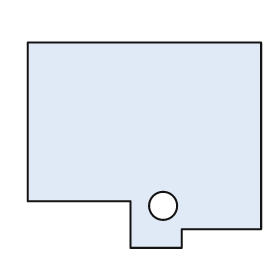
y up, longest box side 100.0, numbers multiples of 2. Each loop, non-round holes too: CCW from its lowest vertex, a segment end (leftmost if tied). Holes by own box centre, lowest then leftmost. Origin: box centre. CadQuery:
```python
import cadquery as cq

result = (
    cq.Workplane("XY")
    .moveTo(-6.0, -44.0)
    .lineTo(16.0, -44.0)
    .lineTo(16.0, -36.0)
    .lineTo(50.0, -36.0)
    .lineTo(50.0, 44.0)
    .lineTo(-50.0, 44.0)
    .lineTo(-50.0, -24.0)
    .lineTo(-6.0, -24.0)
    .close()
    .moveTo(8.0, -26.0)
    .circle(6.0)
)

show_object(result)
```